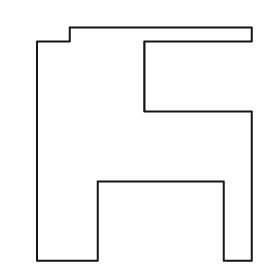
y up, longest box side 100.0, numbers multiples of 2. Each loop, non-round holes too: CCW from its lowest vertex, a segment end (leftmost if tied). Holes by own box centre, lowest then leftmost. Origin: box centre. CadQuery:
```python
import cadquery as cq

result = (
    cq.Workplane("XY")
    .moveTo(-46.0, -50.0)
    .lineTo(-20.0, -50.0)
    .lineTo(-20.0, -16.0)
    .lineTo(34.0, -16.0)
    .lineTo(34.0, -50.0)
    .lineTo(46.0, -50.0)
    .lineTo(46.0, 14.0)
    .lineTo(0.0, 14.0)
    .lineTo(0.0, 44.0)
    .lineTo(46.0, 44.0)
    .lineTo(46.0, 50.0)
    .lineTo(-32.0, 50.0)
    .lineTo(-32.0, 44.0)
    .lineTo(-46.0, 44.0)
    .close()
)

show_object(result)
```